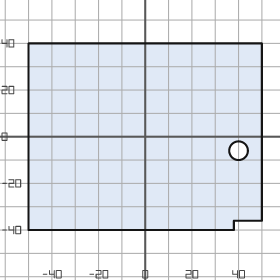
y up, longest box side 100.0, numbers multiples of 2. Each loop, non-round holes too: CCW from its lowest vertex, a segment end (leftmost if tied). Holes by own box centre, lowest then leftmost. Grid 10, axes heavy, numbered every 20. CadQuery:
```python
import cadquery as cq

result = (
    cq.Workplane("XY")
    .moveTo(-50.0, -40.0)
    .lineTo(38.0, -40.0)
    .lineTo(38.0, -36.0)
    .lineTo(50.0, -36.0)
    .lineTo(50.0, 40.0)
    .lineTo(-50.0, 40.0)
    .close()
    .moveTo(40.0, -6.0)
    .circle(4.0)
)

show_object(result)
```